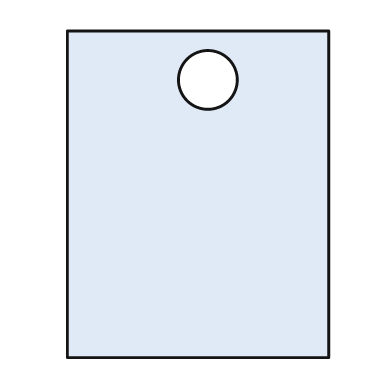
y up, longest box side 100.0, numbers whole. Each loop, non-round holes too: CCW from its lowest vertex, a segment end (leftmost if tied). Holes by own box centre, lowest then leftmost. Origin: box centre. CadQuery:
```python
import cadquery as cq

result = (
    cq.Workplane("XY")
    .moveTo(-40.0, -50.0)
    .lineTo(40.0, -50.0)
    .lineTo(40.0, 50.0)
    .lineTo(-40.0, 50.0)
    .close()
    .moveTo(3.0, 35.0)
    .circle(9.0)
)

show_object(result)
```